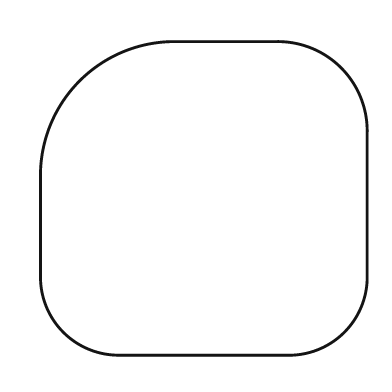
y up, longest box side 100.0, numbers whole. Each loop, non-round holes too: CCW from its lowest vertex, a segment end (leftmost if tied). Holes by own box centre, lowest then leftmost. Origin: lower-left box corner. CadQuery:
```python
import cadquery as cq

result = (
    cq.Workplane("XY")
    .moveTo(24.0, 0.0)
    .lineTo(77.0, 0.0)
    .threePointArc((93.0, 7.0), (100.0, 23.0))
    .lineTo(100.0, 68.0)
    .threePointArc((92.0, 88.0), (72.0, 96.0))
    .lineTo(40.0, 96.0)
    .threePointArc((12.0, 84.0), (0.0, 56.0))
    .lineTo(0.0, 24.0)
    .threePointArc((7.0, 7.0), (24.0, 0.0))
    .close()
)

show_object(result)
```